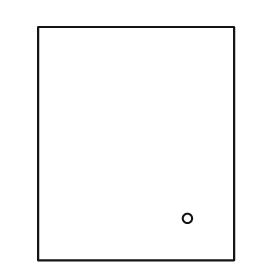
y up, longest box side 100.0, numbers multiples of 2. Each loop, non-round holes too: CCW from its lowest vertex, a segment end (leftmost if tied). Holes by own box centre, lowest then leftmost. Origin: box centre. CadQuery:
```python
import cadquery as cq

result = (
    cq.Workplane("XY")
    .moveTo(-42.0, -50.0)
    .lineTo(42.0, -50.0)
    .lineTo(42.0, 50.0)
    .lineTo(-42.0, 50.0)
    .close()
    .moveTo(22.0, -32.0)
    .circle(2.0)
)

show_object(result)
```